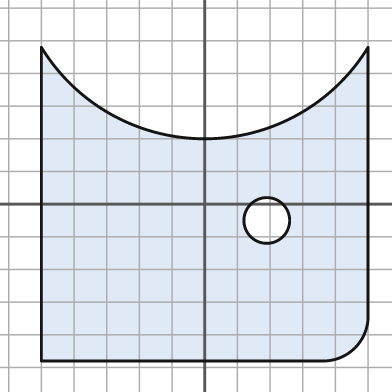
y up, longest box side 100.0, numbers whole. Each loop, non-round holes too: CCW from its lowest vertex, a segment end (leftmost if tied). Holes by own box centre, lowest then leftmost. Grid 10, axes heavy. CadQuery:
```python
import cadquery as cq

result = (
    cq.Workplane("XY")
    .moveTo(-50.0, -48.0)
    .lineTo(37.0, -48.0)
    .threePointArc((46.0, -44.0), (50.0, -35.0))
    .lineTo(50.0, 48.0)
    .threePointArc((0.0, 20.0), (-50.0, 48.0))
    .close()
    .moveTo(19.0, -5.0)
    .circle(7.0)
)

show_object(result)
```